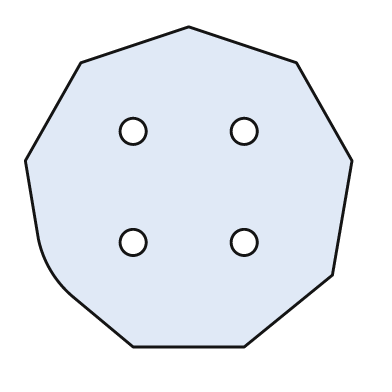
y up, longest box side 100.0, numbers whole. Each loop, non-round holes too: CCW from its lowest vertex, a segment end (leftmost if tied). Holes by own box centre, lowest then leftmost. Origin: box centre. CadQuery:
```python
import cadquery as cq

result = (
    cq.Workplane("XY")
    .moveTo(-17.0, -49.0)
    .lineTo(17.0, -49.0)
    .lineTo(44.0, -27.0)
    .lineTo(50.0, 8.0)
    .lineTo(33.0, 38.0)
    .lineTo(0.0, 49.0)
    .lineTo(-33.0, 38.0)
    .lineTo(-50.0, 8.0)
    .lineTo(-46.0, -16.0)
    .threePointArc((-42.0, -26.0), (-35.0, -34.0))
    .close()
    .moveTo(-17.0, -17.0)
    .circle(4.0)
    .moveTo(17.0, -17.0)
    .circle(4.0)
    .moveTo(-17.0, 17.0)
    .circle(4.0)
    .moveTo(17.0, 17.0)
    .circle(4.0)
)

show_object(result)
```